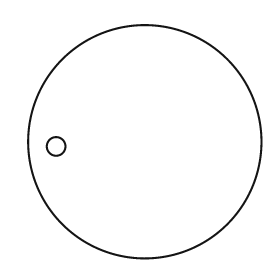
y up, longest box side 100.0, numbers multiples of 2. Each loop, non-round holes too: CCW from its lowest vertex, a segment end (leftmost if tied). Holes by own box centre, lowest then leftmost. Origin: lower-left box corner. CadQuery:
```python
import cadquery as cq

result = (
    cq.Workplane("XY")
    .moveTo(50.0, 50.0)
    .circle(50.0)
    .moveTo(12.0, 48.0)
    .circle(4.0)
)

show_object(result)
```